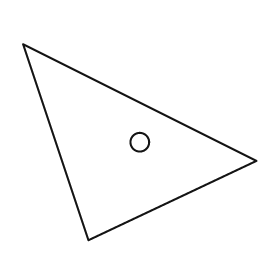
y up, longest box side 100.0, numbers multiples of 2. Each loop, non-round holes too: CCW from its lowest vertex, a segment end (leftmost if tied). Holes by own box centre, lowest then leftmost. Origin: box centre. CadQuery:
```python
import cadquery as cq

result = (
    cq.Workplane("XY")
    .moveTo(-22.0, -42.0)
    .lineTo(50.0, -8.0)
    .lineTo(-50.0, 42.0)
    .close()
    .moveTo(0.0, 0.0)
    .circle(4.0)
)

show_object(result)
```